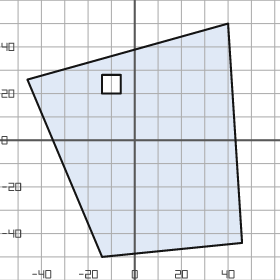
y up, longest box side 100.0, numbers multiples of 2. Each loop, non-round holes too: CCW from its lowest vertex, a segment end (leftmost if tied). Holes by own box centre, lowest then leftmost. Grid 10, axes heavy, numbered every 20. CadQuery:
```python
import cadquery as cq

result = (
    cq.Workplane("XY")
    .moveTo(-14.0, -50.0)
    .lineTo(46.0, -44.0)
    .lineTo(40.0, 50.0)
    .lineTo(-46.0, 26.0)
    .close()
    .moveTo(-14.0, 20.0)
    .lineTo(-6.0, 20.0)
    .lineTo(-6.0, 28.0)
    .lineTo(-14.0, 28.0)
    .close()
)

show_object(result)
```